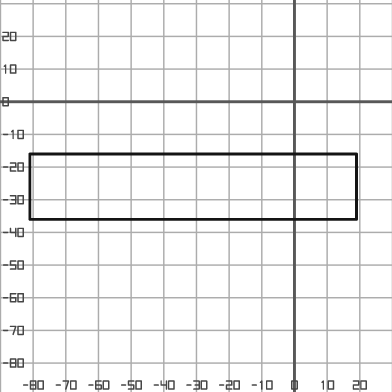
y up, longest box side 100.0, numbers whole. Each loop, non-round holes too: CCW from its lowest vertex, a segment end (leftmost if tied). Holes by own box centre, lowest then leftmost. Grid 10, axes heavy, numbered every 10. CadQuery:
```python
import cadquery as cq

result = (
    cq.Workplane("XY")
    .moveTo(-81.0, -36.0)
    .lineTo(19.0, -36.0)
    .lineTo(19.0, -16.0)
    .lineTo(-81.0, -16.0)
    .close()
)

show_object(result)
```